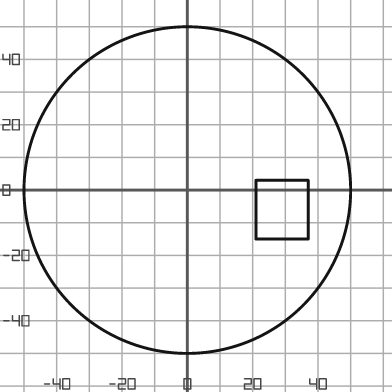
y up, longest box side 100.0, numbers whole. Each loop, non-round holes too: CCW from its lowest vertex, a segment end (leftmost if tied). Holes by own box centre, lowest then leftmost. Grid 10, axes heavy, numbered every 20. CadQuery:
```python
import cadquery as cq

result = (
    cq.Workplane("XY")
    .moveTo(0.0, 0.0)
    .circle(50.0)
    .moveTo(21.0, -15.0)
    .lineTo(37.0, -15.0)
    .lineTo(37.0, 3.0)
    .lineTo(21.0, 3.0)
    .close()
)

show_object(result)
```